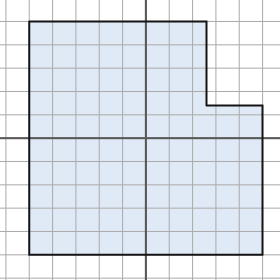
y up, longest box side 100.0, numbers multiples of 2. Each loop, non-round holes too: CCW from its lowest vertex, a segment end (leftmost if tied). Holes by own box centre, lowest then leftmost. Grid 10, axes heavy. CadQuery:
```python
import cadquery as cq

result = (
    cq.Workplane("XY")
    .moveTo(-50.0, -50.0)
    .lineTo(50.0, -50.0)
    .lineTo(50.0, 14.0)
    .lineTo(26.0, 14.0)
    .lineTo(26.0, 50.0)
    .lineTo(-50.0, 50.0)
    .close()
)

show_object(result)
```